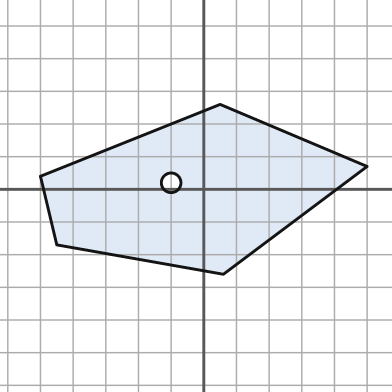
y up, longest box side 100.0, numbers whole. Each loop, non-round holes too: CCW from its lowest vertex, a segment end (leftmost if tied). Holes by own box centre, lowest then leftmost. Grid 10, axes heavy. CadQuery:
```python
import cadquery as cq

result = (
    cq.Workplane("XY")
    .moveTo(6.0, -26.0)
    .lineTo(50.0, 7.0)
    .lineTo(5.0, 26.0)
    .lineTo(-50.0, 4.0)
    .lineTo(-45.0, -17.0)
    .close()
    .moveTo(-10.0, 2.0)
    .circle(3.0)
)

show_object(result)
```